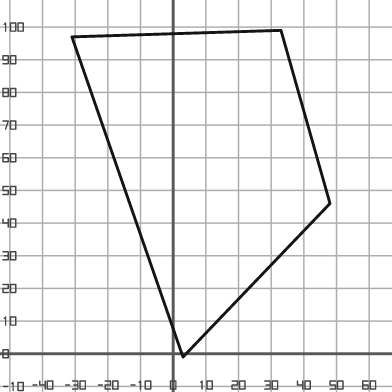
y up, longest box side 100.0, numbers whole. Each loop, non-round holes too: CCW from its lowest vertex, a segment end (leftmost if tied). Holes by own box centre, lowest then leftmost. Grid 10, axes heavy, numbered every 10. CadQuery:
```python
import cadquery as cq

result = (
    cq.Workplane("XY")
    .moveTo(3.0, -1.0)
    .lineTo(48.0, 46.0)
    .lineTo(33.0, 99.0)
    .lineTo(-31.0, 97.0)
    .close()
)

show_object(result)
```